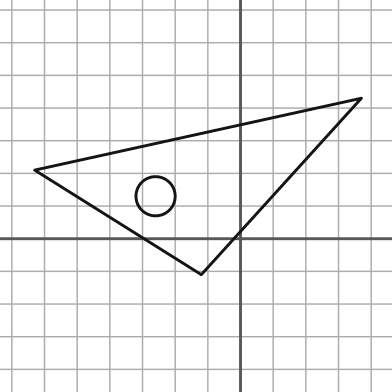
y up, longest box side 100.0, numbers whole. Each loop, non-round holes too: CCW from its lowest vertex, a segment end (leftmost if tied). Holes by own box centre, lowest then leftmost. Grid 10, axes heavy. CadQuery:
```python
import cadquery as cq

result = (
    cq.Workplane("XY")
    .moveTo(-12.0, -11.0)
    .lineTo(37.0, 43.0)
    .lineTo(-63.0, 21.0)
    .close()
    .moveTo(-26.0, 13.0)
    .circle(6.0)
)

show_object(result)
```